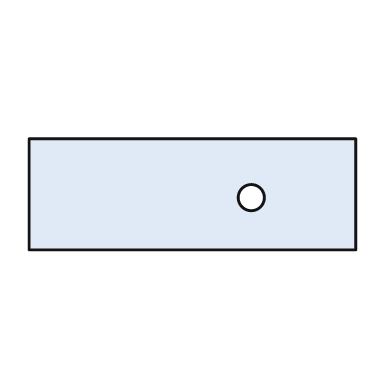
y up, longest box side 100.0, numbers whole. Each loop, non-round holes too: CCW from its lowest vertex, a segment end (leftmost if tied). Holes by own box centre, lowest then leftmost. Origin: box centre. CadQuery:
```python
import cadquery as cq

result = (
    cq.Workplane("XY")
    .moveTo(-50.0, -17.0)
    .lineTo(50.0, -17.0)
    .lineTo(50.0, 17.0)
    .lineTo(-50.0, 17.0)
    .close()
    .moveTo(18.0, -1.0)
    .circle(4.0)
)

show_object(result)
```